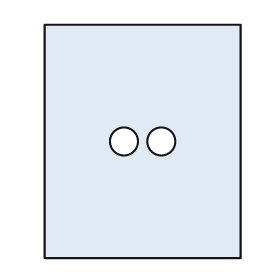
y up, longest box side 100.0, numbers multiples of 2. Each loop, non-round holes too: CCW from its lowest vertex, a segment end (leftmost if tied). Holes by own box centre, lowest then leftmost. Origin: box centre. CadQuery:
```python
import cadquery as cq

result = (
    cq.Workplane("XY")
    .moveTo(-42.0, -50.0)
    .lineTo(42.0, -50.0)
    .lineTo(42.0, 50.0)
    .lineTo(-42.0, 50.0)
    .close()
    .moveTo(-8.0, 0.0)
    .circle(6.0)
    .moveTo(8.0, 0.0)
    .circle(6.0)
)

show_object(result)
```